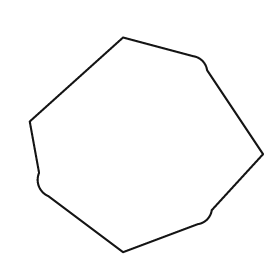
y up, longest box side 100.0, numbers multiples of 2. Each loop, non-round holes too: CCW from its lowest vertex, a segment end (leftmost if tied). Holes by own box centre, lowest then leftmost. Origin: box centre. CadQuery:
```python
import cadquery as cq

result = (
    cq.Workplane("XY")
    .moveTo(-10.0, -46.0)
    .lineTo(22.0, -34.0)
    .threePointArc((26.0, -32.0), (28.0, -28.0))
    .lineTo(50.0, -4.0)
    .lineTo(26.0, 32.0)
    .threePointArc((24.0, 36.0), (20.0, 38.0))
    .lineTo(-10.0, 46.0)
    .lineTo(-50.0, 10.0)
    .lineTo(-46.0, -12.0)
    .threePointArc((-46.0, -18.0), (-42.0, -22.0))
    .close()
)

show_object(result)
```